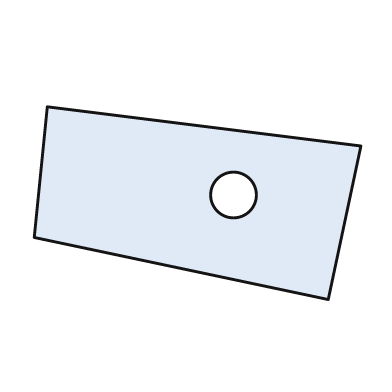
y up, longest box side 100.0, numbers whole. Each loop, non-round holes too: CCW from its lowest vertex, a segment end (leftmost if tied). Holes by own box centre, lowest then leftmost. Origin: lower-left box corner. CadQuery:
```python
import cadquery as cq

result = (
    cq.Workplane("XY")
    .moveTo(90.0, 0.0)
    .lineTo(100.0, 47.0)
    .lineTo(4.0, 59.0)
    .lineTo(0.0, 19.0)
    .close()
    .moveTo(61.0, 32.0)
    .circle(7.0)
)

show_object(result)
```